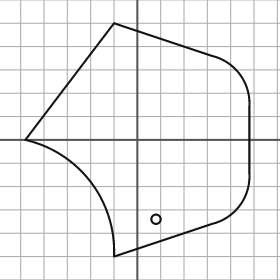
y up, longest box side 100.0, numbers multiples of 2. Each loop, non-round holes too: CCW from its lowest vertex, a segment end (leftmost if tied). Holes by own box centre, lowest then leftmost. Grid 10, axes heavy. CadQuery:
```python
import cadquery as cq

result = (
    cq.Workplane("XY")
    .moveTo(-10.0, -50.0)
    .lineTo(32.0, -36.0)
    .threePointArc((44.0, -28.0), (48.0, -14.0))
    .lineTo(48.0, 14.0)
    .threePointArc((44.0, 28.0), (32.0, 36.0))
    .lineTo(-10.0, 50.0)
    .lineTo(-48.0, 0.0)
    .threePointArc((-20.0, -18.0), (-10.0, -50.0))
    .close()
    .moveTo(8.0, -34.0)
    .circle(2.0)
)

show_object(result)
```